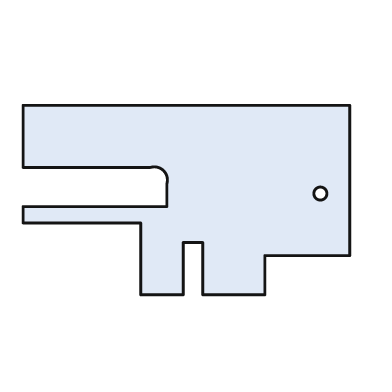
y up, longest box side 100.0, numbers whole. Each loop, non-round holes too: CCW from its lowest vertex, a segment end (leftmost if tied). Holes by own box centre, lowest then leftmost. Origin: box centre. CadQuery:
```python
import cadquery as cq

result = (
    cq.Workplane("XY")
    .moveTo(-14.0, -29.0)
    .lineTo(-1.0, -29.0)
    .lineTo(-1.0, -13.0)
    .lineTo(5.0, -13.0)
    .lineTo(5.0, -29.0)
    .lineTo(24.0, -29.0)
    .lineTo(24.0, -17.0)
    .lineTo(50.0, -17.0)
    .lineTo(50.0, 29.0)
    .lineTo(-50.0, 29.0)
    .lineTo(-50.0, 10.0)
    .lineTo(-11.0, 10.0)
    .threePointArc((-7.0, 9.0), (-6.0, 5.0))
    .lineTo(-6.0, -2.0)
    .lineTo(-50.0, -2.0)
    .lineTo(-50.0, -7.0)
    .lineTo(-14.0, -7.0)
    .close()
    .moveTo(41.0, 2.0)
    .circle(2.0)
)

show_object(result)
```